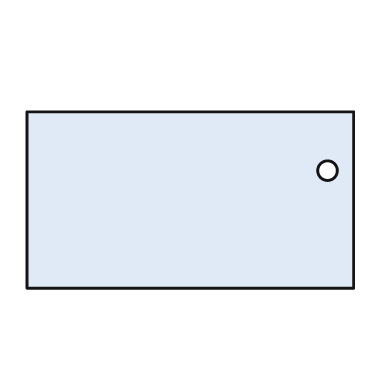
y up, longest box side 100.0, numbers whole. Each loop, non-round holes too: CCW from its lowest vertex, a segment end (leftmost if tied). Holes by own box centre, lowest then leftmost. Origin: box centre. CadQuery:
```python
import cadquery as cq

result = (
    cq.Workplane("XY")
    .moveTo(-50.0, -27.0)
    .lineTo(50.0, -27.0)
    .lineTo(50.0, 27.0)
    .lineTo(-50.0, 27.0)
    .close()
    .moveTo(42.0, 9.0)
    .circle(3.0)
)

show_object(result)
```